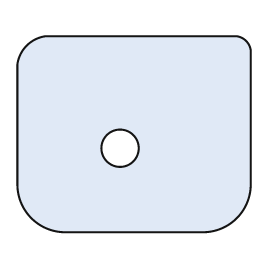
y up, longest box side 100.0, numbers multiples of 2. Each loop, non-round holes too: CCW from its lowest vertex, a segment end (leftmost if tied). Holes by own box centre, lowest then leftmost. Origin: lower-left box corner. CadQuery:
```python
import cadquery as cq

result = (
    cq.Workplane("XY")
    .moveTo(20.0, 0.0)
    .lineTo(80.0, 0.0)
    .threePointArc((94.0, 6.0), (100.0, 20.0))
    .lineTo(100.0, 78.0)
    .threePointArc((98.0, 82.0), (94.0, 84.0))
    .lineTo(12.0, 84.0)
    .threePointArc((4.0, 80.0), (0.0, 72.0))
    .lineTo(0.0, 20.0)
    .threePointArc((6.0, 6.0), (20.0, 0.0))
    .close()
    .moveTo(44.0, 36.0)
    .circle(8.0)
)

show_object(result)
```